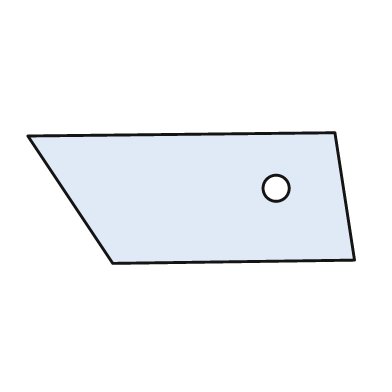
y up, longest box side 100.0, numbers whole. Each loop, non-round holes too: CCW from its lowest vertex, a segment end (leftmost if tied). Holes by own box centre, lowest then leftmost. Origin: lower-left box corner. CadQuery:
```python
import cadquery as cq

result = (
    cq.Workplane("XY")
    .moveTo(26.0, 0.0)
    .lineTo(100.0, 1.0)
    .lineTo(94.0, 40.0)
    .lineTo(0.0, 39.0)
    .close()
    .moveTo(76.0, 23.0)
    .circle(4.0)
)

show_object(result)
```